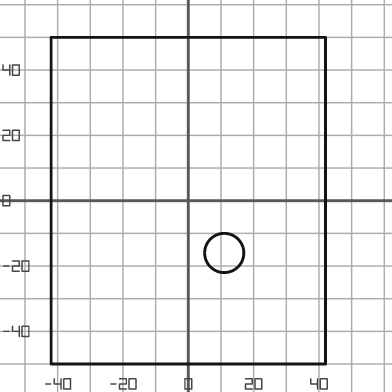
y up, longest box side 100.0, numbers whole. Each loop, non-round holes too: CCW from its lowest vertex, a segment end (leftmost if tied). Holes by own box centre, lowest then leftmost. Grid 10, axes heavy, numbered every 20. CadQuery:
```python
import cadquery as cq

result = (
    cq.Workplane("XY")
    .moveTo(-42.0, -50.0)
    .lineTo(42.0, -50.0)
    .lineTo(42.0, 50.0)
    .lineTo(-42.0, 50.0)
    .close()
    .moveTo(11.0, -16.0)
    .circle(6.0)
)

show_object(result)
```